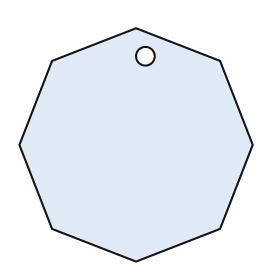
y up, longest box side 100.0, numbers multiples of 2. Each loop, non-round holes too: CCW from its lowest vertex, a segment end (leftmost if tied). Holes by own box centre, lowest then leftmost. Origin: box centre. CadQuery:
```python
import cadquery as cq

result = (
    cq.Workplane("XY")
    .moveTo(0.0, -50.0)
    .lineTo(36.0, -36.0)
    .lineTo(50.0, 0.0)
    .lineTo(36.0, 36.0)
    .lineTo(0.0, 50.0)
    .lineTo(-36.0, 36.0)
    .lineTo(-50.0, 0.0)
    .lineTo(-36.0, -36.0)
    .close()
    .moveTo(4.0, 38.0)
    .circle(4.0)
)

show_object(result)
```